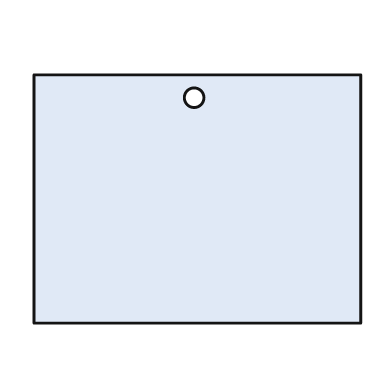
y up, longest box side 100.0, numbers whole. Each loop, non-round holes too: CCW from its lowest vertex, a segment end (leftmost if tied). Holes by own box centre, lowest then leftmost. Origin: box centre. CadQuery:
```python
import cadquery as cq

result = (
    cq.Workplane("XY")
    .moveTo(-50.0, -38.0)
    .lineTo(50.0, -38.0)
    .lineTo(50.0, 38.0)
    .lineTo(-50.0, 38.0)
    .close()
    .moveTo(-1.0, 31.0)
    .circle(3.0)
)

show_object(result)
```